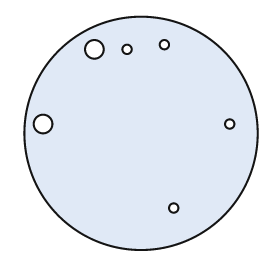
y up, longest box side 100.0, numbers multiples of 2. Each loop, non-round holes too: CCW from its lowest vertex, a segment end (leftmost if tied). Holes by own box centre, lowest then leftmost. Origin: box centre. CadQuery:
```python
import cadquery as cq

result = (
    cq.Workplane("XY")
    .moveTo(0.0, 0.0)
    .circle(50.0)
    .moveTo(14.0, -32.0)
    .circle(2.0)
    .moveTo(-42.0, 4.0)
    .circle(4.0)
    .moveTo(38.0, 4.0)
    .circle(2.0)
    .moveTo(-20.0, 36.0)
    .circle(4.0)
    .moveTo(-6.0, 36.0)
    .circle(2.0)
    .moveTo(10.0, 38.0)
    .circle(2.0)
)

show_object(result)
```